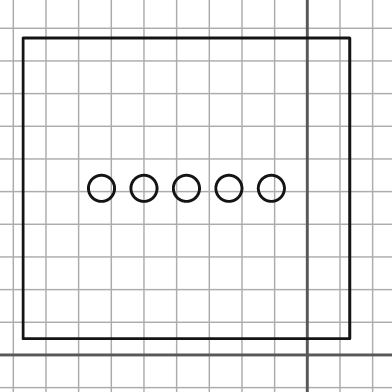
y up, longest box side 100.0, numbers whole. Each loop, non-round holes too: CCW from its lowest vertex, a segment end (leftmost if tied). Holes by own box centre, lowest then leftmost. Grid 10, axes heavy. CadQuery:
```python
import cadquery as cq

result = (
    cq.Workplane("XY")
    .moveTo(-87.0, 5.0)
    .lineTo(13.0, 5.0)
    .lineTo(13.0, 97.0)
    .lineTo(-87.0, 97.0)
    .close()
    .moveTo(-63.0, 51.0)
    .circle(4.0)
    .moveTo(-50.0, 51.0)
    .circle(4.0)
    .moveTo(-37.0, 51.0)
    .circle(4.0)
    .moveTo(-24.0, 51.0)
    .circle(4.0)
    .moveTo(-11.0, 51.0)
    .circle(4.0)
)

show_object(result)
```